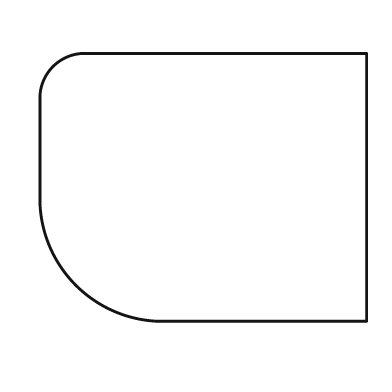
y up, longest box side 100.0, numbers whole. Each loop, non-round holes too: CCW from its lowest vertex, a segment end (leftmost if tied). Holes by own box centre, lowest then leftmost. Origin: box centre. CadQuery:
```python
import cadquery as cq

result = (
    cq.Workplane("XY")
    .moveTo(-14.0, -41.0)
    .lineTo(50.0, -41.0)
    .lineTo(50.0, 41.0)
    .lineTo(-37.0, 41.0)
    .threePointArc((-46.0, 37.0), (-50.0, 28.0))
    .lineTo(-50.0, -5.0)
    .threePointArc((-39.0, -30.0), (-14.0, -41.0))
    .close()
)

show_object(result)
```